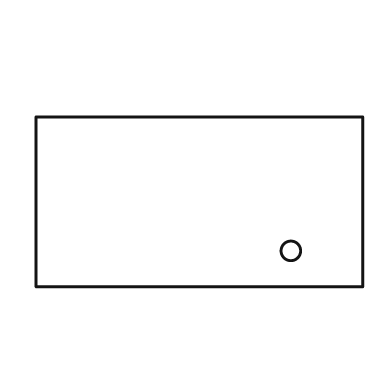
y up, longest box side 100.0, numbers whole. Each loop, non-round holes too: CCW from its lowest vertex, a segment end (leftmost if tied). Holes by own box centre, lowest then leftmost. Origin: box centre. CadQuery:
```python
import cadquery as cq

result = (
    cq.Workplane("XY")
    .moveTo(-50.0, -26.0)
    .lineTo(50.0, -26.0)
    .lineTo(50.0, 26.0)
    .lineTo(-50.0, 26.0)
    .close()
    .moveTo(28.0, -15.0)
    .circle(3.0)
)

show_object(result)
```